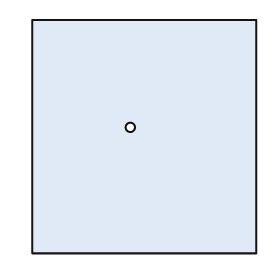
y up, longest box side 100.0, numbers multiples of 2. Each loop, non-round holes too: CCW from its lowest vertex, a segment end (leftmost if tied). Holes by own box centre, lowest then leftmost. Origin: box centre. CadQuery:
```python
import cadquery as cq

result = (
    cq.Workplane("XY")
    .moveTo(-48.0, -50.0)
    .lineTo(48.0, -50.0)
    .lineTo(48.0, 50.0)
    .lineTo(-48.0, 50.0)
    .close()
    .moveTo(-6.0, 4.0)
    .circle(2.0)
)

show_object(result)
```